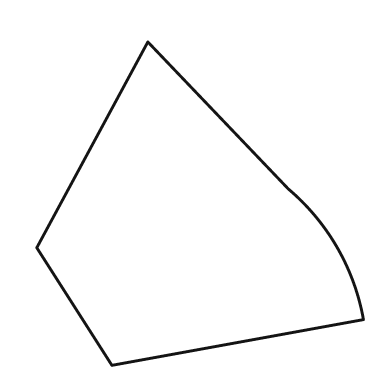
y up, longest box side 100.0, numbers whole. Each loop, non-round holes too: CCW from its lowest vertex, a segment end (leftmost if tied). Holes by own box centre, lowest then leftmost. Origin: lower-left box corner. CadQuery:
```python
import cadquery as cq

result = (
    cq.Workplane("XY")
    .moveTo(23.0, 0.0)
    .lineTo(100.0, 14.0)
    .threePointArc((92.0, 36.0), (77.0, 54.0))
    .lineTo(34.0, 99.0)
    .lineTo(0.0, 36.0)
    .close()
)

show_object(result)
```